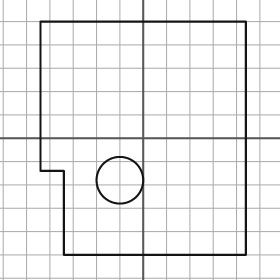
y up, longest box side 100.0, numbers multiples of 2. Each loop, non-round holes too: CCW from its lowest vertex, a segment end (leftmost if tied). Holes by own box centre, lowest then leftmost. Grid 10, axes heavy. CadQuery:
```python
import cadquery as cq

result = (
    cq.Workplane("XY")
    .moveTo(-34.0, -50.0)
    .lineTo(44.0, -50.0)
    .lineTo(44.0, 50.0)
    .lineTo(-44.0, 50.0)
    .lineTo(-44.0, -14.0)
    .lineTo(-34.0, -14.0)
    .close()
    .moveTo(-10.0, -18.0)
    .circle(10.0)
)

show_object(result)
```